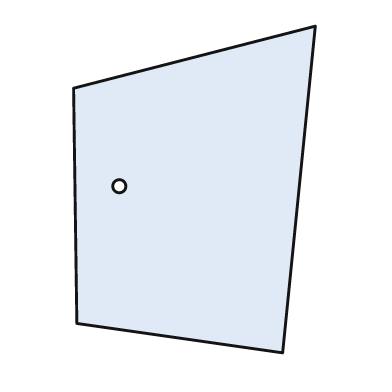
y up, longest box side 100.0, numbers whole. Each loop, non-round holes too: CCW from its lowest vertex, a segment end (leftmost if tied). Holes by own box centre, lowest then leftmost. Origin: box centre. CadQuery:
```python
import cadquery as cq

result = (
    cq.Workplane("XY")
    .moveTo(27.0, -50.0)
    .lineTo(37.0, 50.0)
    .lineTo(-37.0, 31.0)
    .lineTo(-36.0, -41.0)
    .close()
    .moveTo(-23.0, 1.0)
    .circle(2.0)
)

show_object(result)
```